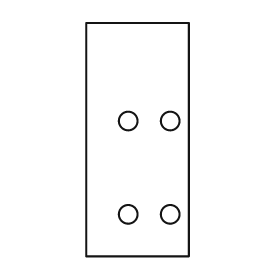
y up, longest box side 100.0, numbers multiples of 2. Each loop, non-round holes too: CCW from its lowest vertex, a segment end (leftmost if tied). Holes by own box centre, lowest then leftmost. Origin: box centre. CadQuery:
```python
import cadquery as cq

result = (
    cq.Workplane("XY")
    .moveTo(-22.0, -50.0)
    .lineTo(22.0, -50.0)
    .lineTo(22.0, 50.0)
    .lineTo(-22.0, 50.0)
    .close()
    .moveTo(-4.0, -32.0)
    .circle(4.0)
    .moveTo(14.0, -32.0)
    .circle(4.0)
    .moveTo(-4.0, 8.0)
    .circle(4.0)
    .moveTo(14.0, 8.0)
    .circle(4.0)
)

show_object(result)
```